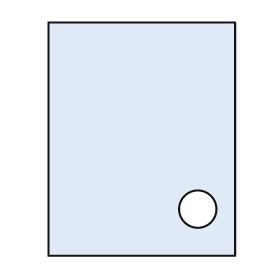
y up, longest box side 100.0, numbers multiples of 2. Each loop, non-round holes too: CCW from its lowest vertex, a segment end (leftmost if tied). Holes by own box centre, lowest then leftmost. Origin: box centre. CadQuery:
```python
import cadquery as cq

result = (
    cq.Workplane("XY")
    .moveTo(-40.0, -50.0)
    .lineTo(40.0, -50.0)
    .lineTo(40.0, 50.0)
    .lineTo(-40.0, 50.0)
    .close()
    .moveTo(24.0, -30.0)
    .circle(8.0)
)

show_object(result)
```